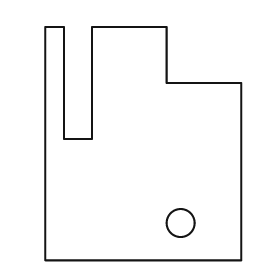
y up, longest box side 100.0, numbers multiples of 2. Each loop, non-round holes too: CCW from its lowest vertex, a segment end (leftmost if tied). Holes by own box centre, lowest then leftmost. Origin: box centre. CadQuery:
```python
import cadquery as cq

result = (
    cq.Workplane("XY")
    .moveTo(-42.0, -50.0)
    .lineTo(42.0, -50.0)
    .lineTo(42.0, 26.0)
    .lineTo(10.0, 26.0)
    .lineTo(10.0, 50.0)
    .lineTo(-22.0, 50.0)
    .lineTo(-22.0, 2.0)
    .lineTo(-34.0, 2.0)
    .lineTo(-34.0, 50.0)
    .lineTo(-42.0, 50.0)
    .close()
    .moveTo(16.0, -34.0)
    .circle(6.0)
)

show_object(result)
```